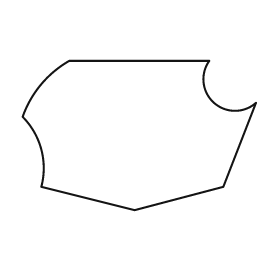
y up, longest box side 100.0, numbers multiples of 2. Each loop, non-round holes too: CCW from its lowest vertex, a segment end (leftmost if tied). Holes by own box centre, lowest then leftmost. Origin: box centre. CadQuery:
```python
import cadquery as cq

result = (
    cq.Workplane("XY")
    .moveTo(-2.0, -32.0)
    .lineTo(36.0, -22.0)
    .lineTo(50.0, 14.0)
    .threePointArc((32.0, 14.0), (30.0, 32.0))
    .lineTo(-30.0, 32.0)
    .threePointArc((-42.0, 22.0), (-50.0, 8.0))
    .threePointArc((-42.0, -6.0), (-42.0, -22.0))
    .close()
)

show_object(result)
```